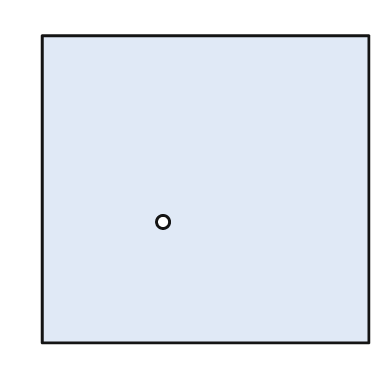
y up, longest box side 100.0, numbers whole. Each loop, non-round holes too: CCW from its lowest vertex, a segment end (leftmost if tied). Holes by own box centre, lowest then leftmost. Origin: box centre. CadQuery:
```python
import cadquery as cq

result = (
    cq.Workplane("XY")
    .moveTo(-50.0, -47.0)
    .lineTo(50.0, -47.0)
    .lineTo(50.0, 47.0)
    .lineTo(-50.0, 47.0)
    .close()
    .moveTo(-13.0, -10.0)
    .circle(2.0)
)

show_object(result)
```